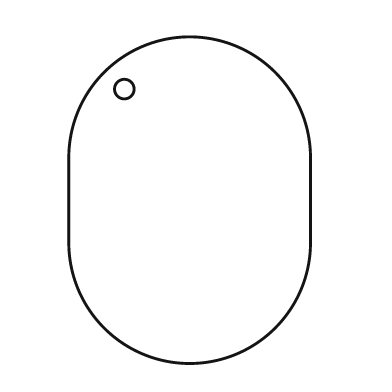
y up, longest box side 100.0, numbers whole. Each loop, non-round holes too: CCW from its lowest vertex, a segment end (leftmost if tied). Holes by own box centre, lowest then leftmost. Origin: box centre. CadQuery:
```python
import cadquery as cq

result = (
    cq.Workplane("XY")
    .moveTo(-37.0, -13.0)
    .threePointArc((0.0, -50.0), (37.0, -13.0))
    .lineTo(37.0, 13.0)
    .threePointArc((0.0, 50.0), (-37.0, 13.0))
    .close()
    .moveTo(-20.0, 34.0)
    .circle(3.0)
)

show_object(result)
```